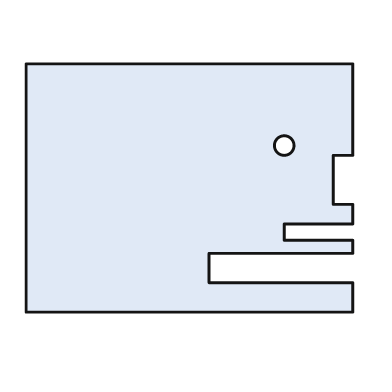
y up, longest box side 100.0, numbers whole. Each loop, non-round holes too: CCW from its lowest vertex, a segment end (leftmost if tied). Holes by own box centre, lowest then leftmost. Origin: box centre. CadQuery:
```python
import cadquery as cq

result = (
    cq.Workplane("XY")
    .moveTo(-50.0, -38.0)
    .lineTo(50.0, -38.0)
    .lineTo(50.0, -29.0)
    .lineTo(6.0, -29.0)
    .lineTo(6.0, -20.0)
    .lineTo(50.0, -20.0)
    .lineTo(50.0, -16.0)
    .lineTo(29.0, -16.0)
    .lineTo(29.0, -11.0)
    .lineTo(50.0, -11.0)
    .lineTo(50.0, -5.0)
    .lineTo(44.0, -5.0)
    .lineTo(44.0, 10.0)
    .lineTo(50.0, 10.0)
    .lineTo(50.0, 38.0)
    .lineTo(-50.0, 38.0)
    .close()
    .moveTo(29.0, 13.0)
    .circle(3.0)
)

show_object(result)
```